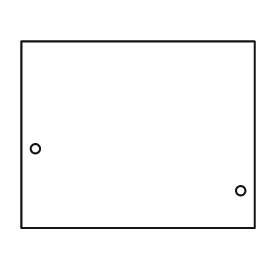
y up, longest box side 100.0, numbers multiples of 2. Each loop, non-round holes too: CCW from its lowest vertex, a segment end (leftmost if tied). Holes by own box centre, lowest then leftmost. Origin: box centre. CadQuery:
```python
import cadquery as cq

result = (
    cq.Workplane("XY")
    .moveTo(-50.0, -40.0)
    .lineTo(50.0, -40.0)
    .lineTo(50.0, 40.0)
    .lineTo(-50.0, 40.0)
    .close()
    .moveTo(44.0, -24.0)
    .circle(2.0)
    .moveTo(-44.0, -6.0)
    .circle(2.0)
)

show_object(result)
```